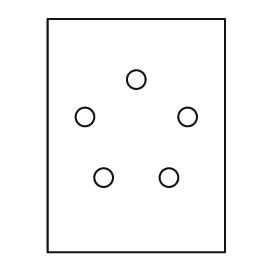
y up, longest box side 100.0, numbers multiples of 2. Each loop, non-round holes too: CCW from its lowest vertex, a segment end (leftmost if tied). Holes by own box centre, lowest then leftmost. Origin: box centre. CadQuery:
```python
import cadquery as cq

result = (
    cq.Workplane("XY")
    .moveTo(-38.0, -50.0)
    .lineTo(38.0, -50.0)
    .lineTo(38.0, 50.0)
    .lineTo(-38.0, 50.0)
    .close()
    .moveTo(-14.0, -18.0)
    .circle(4.0)
    .moveTo(14.0, -18.0)
    .circle(4.0)
    .moveTo(-22.0, 8.0)
    .circle(4.0)
    .moveTo(22.0, 8.0)
    .circle(4.0)
    .moveTo(0.0, 24.0)
    .circle(4.0)
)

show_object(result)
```